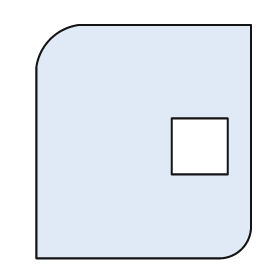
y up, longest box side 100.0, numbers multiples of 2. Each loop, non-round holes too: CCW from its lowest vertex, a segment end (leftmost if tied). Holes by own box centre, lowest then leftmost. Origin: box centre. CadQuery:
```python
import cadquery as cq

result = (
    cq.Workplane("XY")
    .moveTo(-46.0, -50.0)
    .lineTo(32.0, -50.0)
    .threePointArc((42.0, -46.0), (46.0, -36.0))
    .lineTo(46.0, 50.0)
    .lineTo(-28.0, 50.0)
    .threePointArc((-40.0, 44.0), (-46.0, 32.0))
    .close()
    .moveTo(12.0, -14.0)
    .lineTo(36.0, -14.0)
    .lineTo(36.0, 10.0)
    .lineTo(12.0, 10.0)
    .close()
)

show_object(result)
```